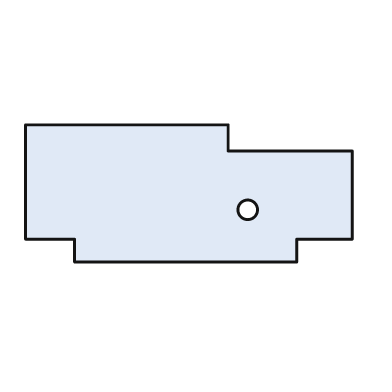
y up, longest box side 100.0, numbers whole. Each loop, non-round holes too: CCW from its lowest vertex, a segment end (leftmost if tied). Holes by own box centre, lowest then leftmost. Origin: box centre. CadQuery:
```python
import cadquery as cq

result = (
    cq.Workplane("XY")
    .moveTo(-35.0, -21.0)
    .lineTo(33.0, -21.0)
    .lineTo(33.0, -14.0)
    .lineTo(50.0, -14.0)
    .lineTo(50.0, 13.0)
    .lineTo(12.0, 13.0)
    .lineTo(12.0, 21.0)
    .lineTo(-50.0, 21.0)
    .lineTo(-50.0, -14.0)
    .lineTo(-35.0, -14.0)
    .close()
    .moveTo(18.0, -5.0)
    .circle(3.0)
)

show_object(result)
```